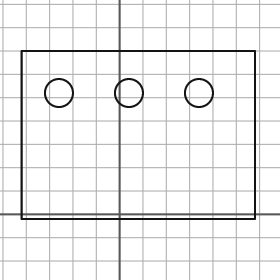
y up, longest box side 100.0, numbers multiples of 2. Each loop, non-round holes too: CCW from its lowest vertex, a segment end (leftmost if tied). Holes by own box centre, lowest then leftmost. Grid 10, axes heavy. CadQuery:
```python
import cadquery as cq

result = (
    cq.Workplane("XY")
    .moveTo(-42.0, -2.0)
    .lineTo(58.0, -2.0)
    .lineTo(58.0, 70.0)
    .lineTo(-42.0, 70.0)
    .close()
    .moveTo(-26.0, 52.0)
    .circle(6.0)
    .moveTo(4.0, 52.0)
    .circle(6.0)
    .moveTo(34.0, 52.0)
    .circle(6.0)
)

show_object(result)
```